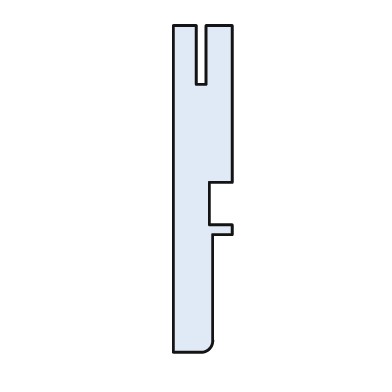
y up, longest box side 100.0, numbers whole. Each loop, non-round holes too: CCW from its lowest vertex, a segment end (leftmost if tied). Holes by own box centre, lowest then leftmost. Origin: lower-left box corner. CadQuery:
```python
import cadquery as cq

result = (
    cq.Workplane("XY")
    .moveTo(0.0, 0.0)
    .lineTo(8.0, 0.0)
    .threePointArc((11.0, 1.0), (12.0, 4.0))
    .lineTo(12.0, 36.0)
    .lineTo(18.0, 36.0)
    .lineTo(18.0, 39.0)
    .lineTo(11.0, 39.0)
    .lineTo(11.0, 52.0)
    .lineTo(18.0, 52.0)
    .lineTo(18.0, 100.0)
    .lineTo(10.0, 100.0)
    .lineTo(10.0, 82.0)
    .lineTo(7.0, 82.0)
    .lineTo(7.0, 100.0)
    .lineTo(0.0, 100.0)
    .close()
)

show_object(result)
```